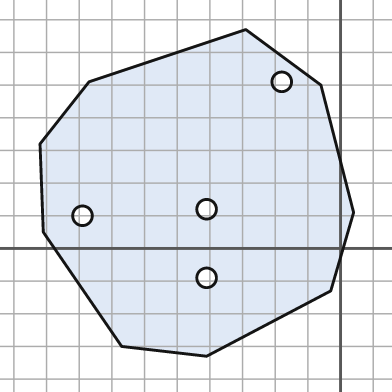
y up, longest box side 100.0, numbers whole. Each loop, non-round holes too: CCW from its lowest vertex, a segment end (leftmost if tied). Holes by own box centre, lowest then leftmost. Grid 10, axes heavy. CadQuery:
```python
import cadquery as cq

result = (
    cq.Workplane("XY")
    .moveTo(-41.0, -33.0)
    .lineTo(-3.0, -13.0)
    .lineTo(4.0, 11.0)
    .lineTo(-6.0, 50.0)
    .lineTo(-29.0, 67.0)
    .lineTo(-77.0, 51.0)
    .lineTo(-92.0, 32.0)
    .lineTo(-91.0, 5.0)
    .lineTo(-67.0, -30.0)
    .close()
    .moveTo(-41.0, -9.0)
    .circle(3.0)
    .moveTo(-79.0, 10.0)
    .circle(3.0)
    .moveTo(-41.0, 12.0)
    .circle(3.0)
    .moveTo(-18.0, 51.0)
    .circle(3.0)
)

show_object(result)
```